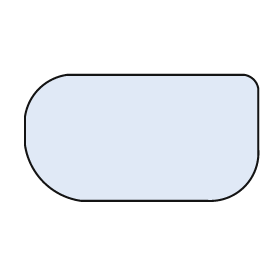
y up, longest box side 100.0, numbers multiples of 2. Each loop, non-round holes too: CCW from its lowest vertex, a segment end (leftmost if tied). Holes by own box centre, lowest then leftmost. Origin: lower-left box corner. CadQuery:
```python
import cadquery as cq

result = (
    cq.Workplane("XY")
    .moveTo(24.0, 0.0)
    .lineTo(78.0, 0.0)
    .threePointArc((94.0, 6.0), (100.0, 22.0))
    .lineTo(100.0, 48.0)
    .threePointArc((98.0, 52.0), (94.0, 54.0))
    .lineTo(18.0, 54.0)
    .threePointArc((6.0, 48.0), (0.0, 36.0))
    .lineTo(0.0, 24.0)
    .threePointArc((8.0, 8.0), (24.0, 0.0))
    .close()
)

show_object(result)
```